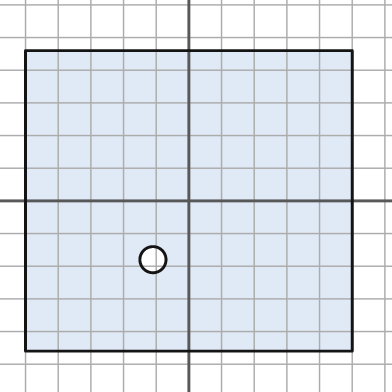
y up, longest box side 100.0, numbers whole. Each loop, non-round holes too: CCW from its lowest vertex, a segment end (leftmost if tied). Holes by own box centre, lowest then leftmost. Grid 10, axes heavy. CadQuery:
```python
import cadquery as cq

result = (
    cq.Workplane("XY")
    .moveTo(-50.0, -46.0)
    .lineTo(50.0, -46.0)
    .lineTo(50.0, 46.0)
    .lineTo(-50.0, 46.0)
    .close()
    .moveTo(-11.0, -18.0)
    .circle(4.0)
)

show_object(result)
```